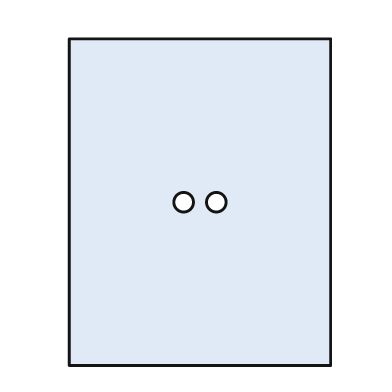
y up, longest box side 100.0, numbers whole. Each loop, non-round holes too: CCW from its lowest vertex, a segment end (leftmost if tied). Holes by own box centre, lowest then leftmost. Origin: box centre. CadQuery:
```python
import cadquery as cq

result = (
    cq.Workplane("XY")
    .moveTo(-40.0, -50.0)
    .lineTo(40.0, -50.0)
    .lineTo(40.0, 50.0)
    .lineTo(-40.0, 50.0)
    .close()
    .moveTo(-5.0, 0.0)
    .circle(3.0)
    .moveTo(5.0, 0.0)
    .circle(3.0)
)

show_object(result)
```